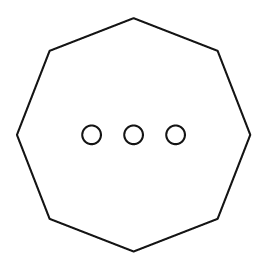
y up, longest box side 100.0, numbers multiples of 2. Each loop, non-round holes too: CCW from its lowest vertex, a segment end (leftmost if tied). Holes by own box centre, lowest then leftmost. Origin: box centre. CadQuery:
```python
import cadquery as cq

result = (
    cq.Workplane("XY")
    .moveTo(0.0, -50.0)
    .lineTo(36.0, -36.0)
    .lineTo(50.0, 0.0)
    .lineTo(36.0, 36.0)
    .lineTo(0.0, 50.0)
    .lineTo(-36.0, 36.0)
    .lineTo(-50.0, 0.0)
    .lineTo(-36.0, -36.0)
    .close()
    .moveTo(-18.0, 0.0)
    .circle(4.0)
    .moveTo(0.0, 0.0)
    .circle(4.0)
    .moveTo(18.0, 0.0)
    .circle(4.0)
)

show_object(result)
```